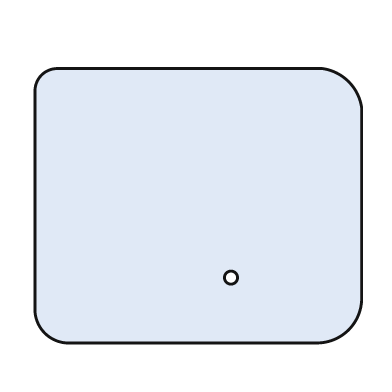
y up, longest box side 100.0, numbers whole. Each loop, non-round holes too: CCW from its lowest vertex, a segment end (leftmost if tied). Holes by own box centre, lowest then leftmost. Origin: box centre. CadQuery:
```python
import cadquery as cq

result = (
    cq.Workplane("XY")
    .moveTo(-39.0, -42.0)
    .lineTo(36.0, -42.0)
    .threePointArc((46.0, -38.0), (50.0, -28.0))
    .lineTo(50.0, 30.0)
    .threePointArc((46.0, 38.0), (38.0, 42.0))
    .lineTo(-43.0, 42.0)
    .threePointArc((-48.0, 40.0), (-50.0, 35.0))
    .lineTo(-50.0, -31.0)
    .threePointArc((-47.0, -39.0), (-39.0, -42.0))
    .close()
    .moveTo(10.0, -22.0)
    .circle(2.0)
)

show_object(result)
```